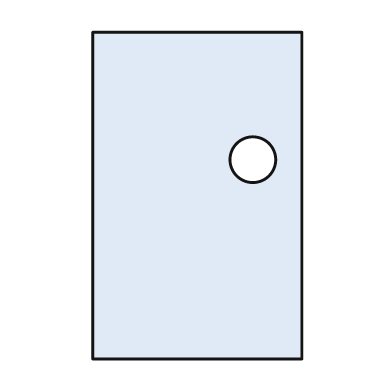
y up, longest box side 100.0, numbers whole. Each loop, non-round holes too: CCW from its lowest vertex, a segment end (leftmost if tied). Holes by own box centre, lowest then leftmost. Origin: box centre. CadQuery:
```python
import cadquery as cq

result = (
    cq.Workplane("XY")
    .moveTo(-32.0, -50.0)
    .lineTo(32.0, -50.0)
    .lineTo(32.0, 50.0)
    .lineTo(-32.0, 50.0)
    .close()
    .moveTo(17.0, 11.0)
    .circle(7.0)
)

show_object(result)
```